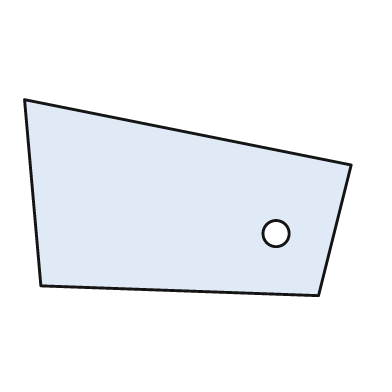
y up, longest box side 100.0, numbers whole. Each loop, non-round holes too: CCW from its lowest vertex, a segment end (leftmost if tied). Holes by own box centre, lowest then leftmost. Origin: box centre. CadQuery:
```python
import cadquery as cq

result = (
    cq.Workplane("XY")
    .moveTo(40.0, -30.0)
    .lineTo(50.0, 10.0)
    .lineTo(-50.0, 30.0)
    .lineTo(-45.0, -27.0)
    .close()
    .moveTo(27.0, -11.0)
    .circle(4.0)
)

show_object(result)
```